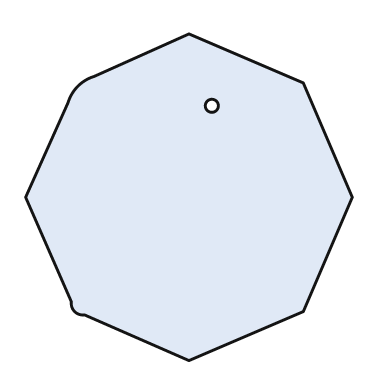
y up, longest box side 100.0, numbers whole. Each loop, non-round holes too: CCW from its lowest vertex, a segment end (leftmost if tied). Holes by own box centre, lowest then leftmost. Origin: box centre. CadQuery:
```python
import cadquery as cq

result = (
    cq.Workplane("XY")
    .moveTo(0.0, -50.0)
    .lineTo(35.0, -35.0)
    .lineTo(50.0, 0.0)
    .lineTo(35.0, 35.0)
    .lineTo(0.0, 50.0)
    .lineTo(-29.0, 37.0)
    .threePointArc((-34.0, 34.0), (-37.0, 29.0))
    .lineTo(-50.0, 0.0)
    .lineTo(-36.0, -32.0)
    .threePointArc((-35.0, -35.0), (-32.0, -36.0))
    .close()
    .moveTo(7.0, 28.0)
    .circle(2.0)
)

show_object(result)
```